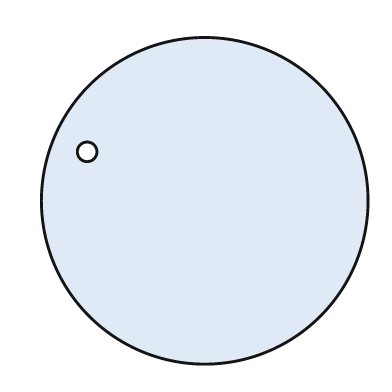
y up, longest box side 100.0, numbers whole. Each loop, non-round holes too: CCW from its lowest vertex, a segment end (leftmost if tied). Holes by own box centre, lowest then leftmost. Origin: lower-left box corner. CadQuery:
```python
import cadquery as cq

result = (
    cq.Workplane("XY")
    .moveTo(50.0, 50.0)
    .circle(50.0)
    .moveTo(14.0, 65.0)
    .circle(3.0)
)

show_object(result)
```